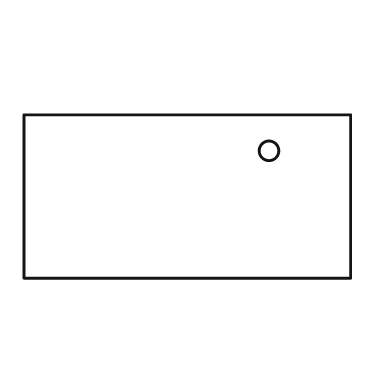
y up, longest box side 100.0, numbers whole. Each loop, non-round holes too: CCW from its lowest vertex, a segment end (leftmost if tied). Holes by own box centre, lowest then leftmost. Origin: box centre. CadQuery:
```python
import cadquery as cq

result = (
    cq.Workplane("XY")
    .moveTo(-50.0, -25.0)
    .lineTo(50.0, -25.0)
    .lineTo(50.0, 25.0)
    .lineTo(-50.0, 25.0)
    .close()
    .moveTo(25.0, 14.0)
    .circle(3.0)
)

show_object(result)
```